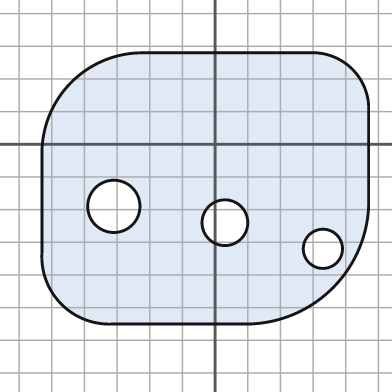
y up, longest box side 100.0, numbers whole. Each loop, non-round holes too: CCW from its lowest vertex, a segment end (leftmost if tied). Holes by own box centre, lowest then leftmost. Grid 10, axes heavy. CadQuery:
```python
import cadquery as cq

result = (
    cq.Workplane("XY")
    .moveTo(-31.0, -55.0)
    .lineTo(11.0, -55.0)
    .threePointArc((36.0, -44.0), (47.0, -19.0))
    .lineTo(47.0, 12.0)
    .threePointArc((42.0, 23.0), (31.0, 28.0))
    .lineTo(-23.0, 28.0)
    .threePointArc((-44.0, 19.0), (-53.0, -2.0))
    .lineTo(-53.0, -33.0)
    .threePointArc((-47.0, -49.0), (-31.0, -55.0))
    .close()
    .moveTo(33.0, -32.0)
    .circle(6.0)
    .moveTo(3.0, -24.0)
    .circle(7.0)
    .moveTo(-31.0, -19.0)
    .circle(8.0)
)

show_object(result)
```